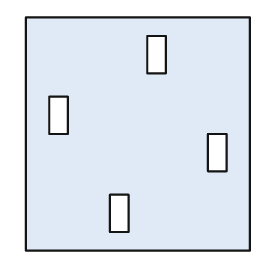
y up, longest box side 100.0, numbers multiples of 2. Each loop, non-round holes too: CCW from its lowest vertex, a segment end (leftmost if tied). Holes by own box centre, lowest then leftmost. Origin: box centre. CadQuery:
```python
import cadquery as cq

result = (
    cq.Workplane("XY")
    .moveTo(-48.0, -50.0)
    .lineTo(48.0, -50.0)
    .lineTo(48.0, 50.0)
    .lineTo(-48.0, 50.0)
    .close()
    .moveTo(-12.0, -42.0)
    .lineTo(-4.0, -42.0)
    .lineTo(-4.0, -26.0)
    .lineTo(-12.0, -26.0)
    .close()
    .moveTo(30.0, -16.0)
    .lineTo(38.0, -16.0)
    .lineTo(38.0, 0.0)
    .lineTo(30.0, 0.0)
    .close()
    .moveTo(-38.0, 0.0)
    .lineTo(-30.0, 0.0)
    .lineTo(-30.0, 16.0)
    .lineTo(-38.0, 16.0)
    .close()
    .moveTo(4.0, 26.0)
    .lineTo(12.0, 26.0)
    .lineTo(12.0, 42.0)
    .lineTo(4.0, 42.0)
    .close()
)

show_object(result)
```